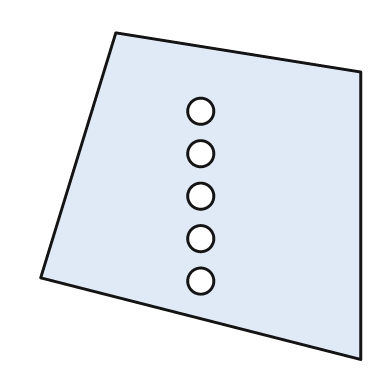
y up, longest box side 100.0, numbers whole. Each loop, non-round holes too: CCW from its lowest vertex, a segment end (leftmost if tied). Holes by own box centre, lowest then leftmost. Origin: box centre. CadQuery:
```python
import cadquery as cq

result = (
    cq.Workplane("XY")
    .moveTo(49.0, -50.0)
    .lineTo(49.0, 38.0)
    .lineTo(-26.0, 50.0)
    .lineTo(-49.0, -25.0)
    .close()
    .moveTo(0.0, -26.0)
    .circle(4.0)
    .moveTo(0.0, -13.0)
    .circle(4.0)
    .moveTo(0.0, 0.0)
    .circle(4.0)
    .moveTo(0.0, 13.0)
    .circle(4.0)
    .moveTo(0.0, 26.0)
    .circle(4.0)
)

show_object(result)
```